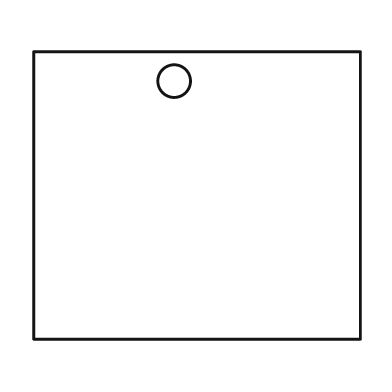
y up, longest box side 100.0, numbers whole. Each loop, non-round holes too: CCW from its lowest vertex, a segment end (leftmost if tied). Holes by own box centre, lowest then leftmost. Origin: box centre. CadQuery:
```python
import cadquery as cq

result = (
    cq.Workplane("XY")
    .moveTo(-50.0, -44.0)
    .lineTo(50.0, -44.0)
    .lineTo(50.0, 44.0)
    .lineTo(-50.0, 44.0)
    .close()
    .moveTo(-7.0, 35.0)
    .circle(5.0)
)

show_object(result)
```